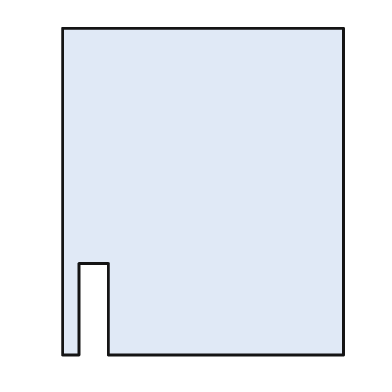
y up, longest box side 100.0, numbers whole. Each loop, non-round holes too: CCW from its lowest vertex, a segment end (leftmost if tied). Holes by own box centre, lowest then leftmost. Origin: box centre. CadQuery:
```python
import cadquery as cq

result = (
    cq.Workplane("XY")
    .moveTo(-43.0, -50.0)
    .lineTo(-38.0, -50.0)
    .lineTo(-38.0, -22.0)
    .lineTo(-29.0, -22.0)
    .lineTo(-29.0, -50.0)
    .lineTo(43.0, -50.0)
    .lineTo(43.0, 50.0)
    .lineTo(-43.0, 50.0)
    .close()
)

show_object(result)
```